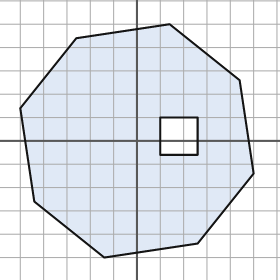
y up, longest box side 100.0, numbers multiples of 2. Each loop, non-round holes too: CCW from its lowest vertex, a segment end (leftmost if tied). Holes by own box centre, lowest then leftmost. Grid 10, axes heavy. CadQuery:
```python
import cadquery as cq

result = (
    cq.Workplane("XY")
    .moveTo(-14.0, -50.0)
    .lineTo(26.0, -44.0)
    .lineTo(50.0, -14.0)
    .lineTo(44.0, 26.0)
    .lineTo(14.0, 50.0)
    .lineTo(-26.0, 44.0)
    .lineTo(-50.0, 14.0)
    .lineTo(-44.0, -26.0)
    .close()
    .moveTo(10.0, -6.0)
    .lineTo(26.0, -6.0)
    .lineTo(26.0, 10.0)
    .lineTo(10.0, 10.0)
    .close()
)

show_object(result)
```